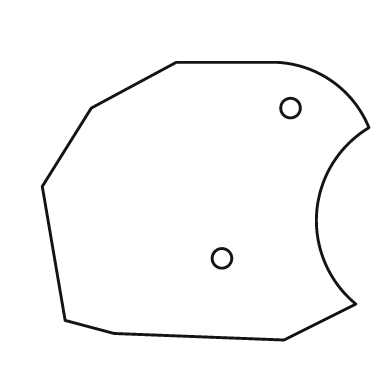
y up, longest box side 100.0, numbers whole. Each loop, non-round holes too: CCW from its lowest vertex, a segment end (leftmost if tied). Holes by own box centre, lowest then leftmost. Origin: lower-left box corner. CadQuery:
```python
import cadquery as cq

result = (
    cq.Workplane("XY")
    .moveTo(74.0, 0.0)
    .lineTo(96.0, 11.0)
    .threePointArc((84.0, 39.0), (100.0, 65.0))
    .threePointArc((89.0, 79.0), (72.0, 85.0))
    .lineTo(41.0, 85.0)
    .lineTo(15.0, 71.0)
    .lineTo(0.0, 47.0)
    .lineTo(7.0, 6.0)
    .lineTo(22.0, 2.0)
    .close()
    .moveTo(55.0, 25.0)
    .circle(3.0)
    .moveTo(76.0, 71.0)
    .circle(3.0)
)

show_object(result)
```